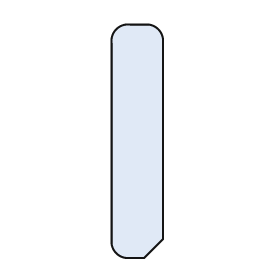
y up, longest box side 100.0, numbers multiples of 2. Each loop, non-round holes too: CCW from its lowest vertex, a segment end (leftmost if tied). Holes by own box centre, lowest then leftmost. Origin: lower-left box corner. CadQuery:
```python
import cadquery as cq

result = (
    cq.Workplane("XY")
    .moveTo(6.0, 0.0)
    .lineTo(14.0, 0.0)
    .lineTo(22.0, 8.0)
    .lineTo(22.0, 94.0)
    .threePointArc((20.0, 98.0), (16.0, 100.0))
    .lineTo(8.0, 100.0)
    .threePointArc((2.0, 98.0), (0.0, 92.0))
    .lineTo(0.0, 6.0)
    .threePointArc((2.0, 2.0), (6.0, 0.0))
    .close()
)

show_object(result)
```